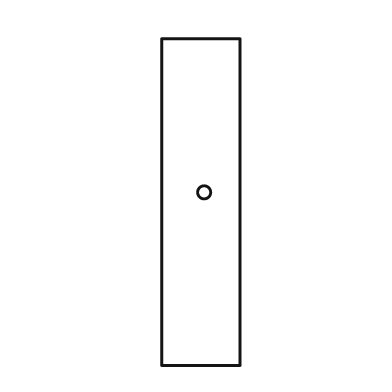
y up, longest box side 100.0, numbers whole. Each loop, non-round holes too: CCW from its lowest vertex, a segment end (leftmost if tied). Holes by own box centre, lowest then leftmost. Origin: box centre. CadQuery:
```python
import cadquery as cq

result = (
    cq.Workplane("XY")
    .moveTo(-12.0, -50.0)
    .lineTo(12.0, -50.0)
    .lineTo(12.0, 50.0)
    .lineTo(-12.0, 50.0)
    .close()
    .moveTo(1.0, 3.0)
    .circle(2.0)
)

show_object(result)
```